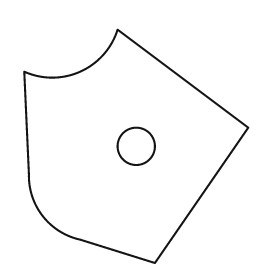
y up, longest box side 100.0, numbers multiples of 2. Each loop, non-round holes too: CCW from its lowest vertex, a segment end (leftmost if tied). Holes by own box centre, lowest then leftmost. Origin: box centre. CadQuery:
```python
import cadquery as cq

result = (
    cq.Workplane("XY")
    .moveTo(8.0, -50.0)
    .lineTo(48.0, 8.0)
    .lineTo(-8.0, 50.0)
    .threePointArc((-24.0, 32.0), (-48.0, 32.0))
    .lineTo(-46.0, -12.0)
    .threePointArc((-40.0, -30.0), (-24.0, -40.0))
    .close()
    .moveTo(0.0, 0.0)
    .circle(8.0)
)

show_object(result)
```